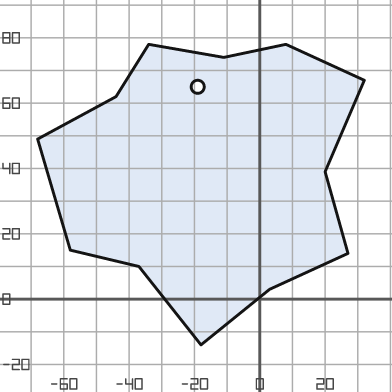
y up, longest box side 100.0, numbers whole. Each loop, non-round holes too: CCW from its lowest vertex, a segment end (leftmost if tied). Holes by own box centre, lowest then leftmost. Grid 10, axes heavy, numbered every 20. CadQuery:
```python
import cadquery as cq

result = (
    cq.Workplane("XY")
    .moveTo(-18.0, -14.0)
    .lineTo(3.0, 3.0)
    .lineTo(27.0, 14.0)
    .lineTo(20.0, 39.0)
    .lineTo(32.0, 67.0)
    .lineTo(8.0, 78.0)
    .lineTo(-11.0, 74.0)
    .lineTo(-34.0, 78.0)
    .lineTo(-44.0, 62.0)
    .lineTo(-68.0, 49.0)
    .lineTo(-58.0, 15.0)
    .lineTo(-37.0, 10.0)
    .close()
    .moveTo(-19.0, 65.0)
    .circle(2.0)
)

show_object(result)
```